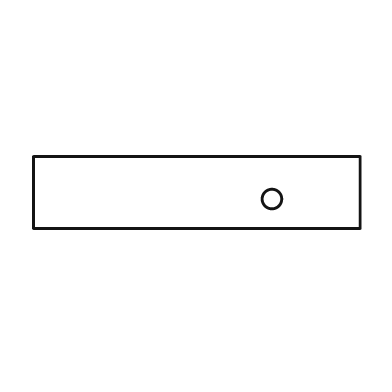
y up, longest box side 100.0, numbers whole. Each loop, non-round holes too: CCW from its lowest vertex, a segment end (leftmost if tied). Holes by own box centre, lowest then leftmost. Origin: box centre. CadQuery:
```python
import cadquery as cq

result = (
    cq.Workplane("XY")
    .moveTo(-50.0, -11.0)
    .lineTo(50.0, -11.0)
    .lineTo(50.0, 11.0)
    .lineTo(-50.0, 11.0)
    .close()
    .moveTo(23.0, -2.0)
    .circle(3.0)
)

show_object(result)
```